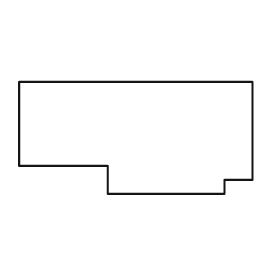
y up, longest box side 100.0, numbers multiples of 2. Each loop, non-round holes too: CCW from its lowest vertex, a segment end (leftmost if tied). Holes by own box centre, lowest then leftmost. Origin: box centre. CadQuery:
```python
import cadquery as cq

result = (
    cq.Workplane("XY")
    .moveTo(-12.0, -24.0)
    .lineTo(38.0, -24.0)
    .lineTo(38.0, -18.0)
    .lineTo(50.0, -18.0)
    .lineTo(50.0, 24.0)
    .lineTo(-50.0, 24.0)
    .lineTo(-50.0, -12.0)
    .lineTo(-12.0, -12.0)
    .close()
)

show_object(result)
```